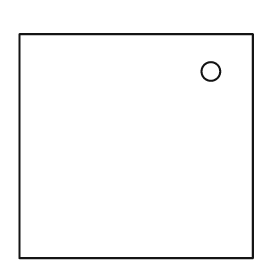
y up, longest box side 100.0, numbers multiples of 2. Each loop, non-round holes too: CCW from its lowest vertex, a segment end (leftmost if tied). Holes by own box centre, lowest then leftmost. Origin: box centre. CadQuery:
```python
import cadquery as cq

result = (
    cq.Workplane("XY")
    .moveTo(-50.0, -48.0)
    .lineTo(50.0, -48.0)
    .lineTo(50.0, 48.0)
    .lineTo(-50.0, 48.0)
    .close()
    .moveTo(32.0, 32.0)
    .circle(4.0)
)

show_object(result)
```